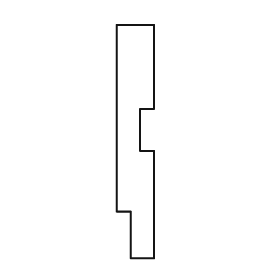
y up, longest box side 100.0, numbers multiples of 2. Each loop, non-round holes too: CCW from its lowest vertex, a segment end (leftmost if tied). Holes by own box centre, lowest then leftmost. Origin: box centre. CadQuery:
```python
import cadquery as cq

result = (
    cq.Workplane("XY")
    .moveTo(-2.0, -50.0)
    .lineTo(8.0, -50.0)
    .lineTo(8.0, -4.0)
    .lineTo(2.0, -4.0)
    .lineTo(2.0, 14.0)
    .lineTo(8.0, 14.0)
    .lineTo(8.0, 50.0)
    .lineTo(-8.0, 50.0)
    .lineTo(-8.0, -30.0)
    .lineTo(-2.0, -30.0)
    .close()
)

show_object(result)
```